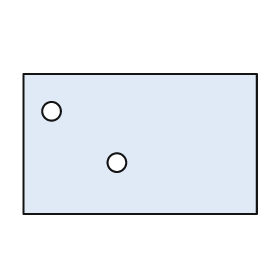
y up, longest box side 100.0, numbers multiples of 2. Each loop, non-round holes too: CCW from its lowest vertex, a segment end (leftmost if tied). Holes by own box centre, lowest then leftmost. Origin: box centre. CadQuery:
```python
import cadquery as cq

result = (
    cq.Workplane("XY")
    .moveTo(-50.0, -30.0)
    .lineTo(50.0, -30.0)
    .lineTo(50.0, 30.0)
    .lineTo(-50.0, 30.0)
    .close()
    .moveTo(-10.0, -8.0)
    .circle(4.0)
    .moveTo(-38.0, 14.0)
    .circle(4.0)
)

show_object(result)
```